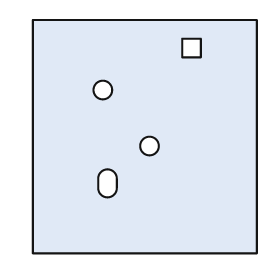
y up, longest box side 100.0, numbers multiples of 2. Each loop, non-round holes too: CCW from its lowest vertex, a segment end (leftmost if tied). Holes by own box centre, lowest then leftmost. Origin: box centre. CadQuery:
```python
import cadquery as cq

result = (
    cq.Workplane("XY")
    .moveTo(-48.0, -50.0)
    .lineTo(48.0, -50.0)
    .lineTo(48.0, 50.0)
    .lineTo(-48.0, 50.0)
    .close()
    .moveTo(-20.0, -22.0)
    .threePointArc((-16.0, -26.0), (-12.0, -22.0))
    .lineTo(-12.0, -18.0)
    .threePointArc((-16.0, -14.0), (-20.0, -18.0))
    .close()
    .moveTo(2.0, -4.0)
    .circle(4.0)
    .moveTo(-18.0, 20.0)
    .circle(4.0)
    .moveTo(16.0, 34.0)
    .lineTo(24.0, 34.0)
    .lineTo(24.0, 42.0)
    .lineTo(16.0, 42.0)
    .close()
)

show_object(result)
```